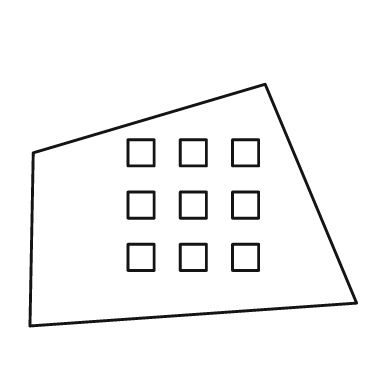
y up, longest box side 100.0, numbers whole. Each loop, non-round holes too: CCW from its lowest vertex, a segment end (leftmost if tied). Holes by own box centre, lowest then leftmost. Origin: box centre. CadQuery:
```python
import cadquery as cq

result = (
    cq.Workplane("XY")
    .moveTo(-50.0, -37.0)
    .lineTo(50.0, -30.0)
    .lineTo(22.0, 37.0)
    .lineTo(-49.0, 16.0)
    .close()
    .moveTo(-20.0, -20.0)
    .lineTo(-12.0, -20.0)
    .lineTo(-12.0, -12.0)
    .lineTo(-20.0, -12.0)
    .close()
    .moveTo(-4.0, -20.0)
    .lineTo(4.0, -20.0)
    .lineTo(4.0, -12.0)
    .lineTo(-4.0, -12.0)
    .close()
    .moveTo(12.0, -20.0)
    .lineTo(20.0, -20.0)
    .lineTo(20.0, -12.0)
    .lineTo(12.0, -12.0)
    .close()
    .moveTo(-20.0, -4.0)
    .lineTo(-12.0, -4.0)
    .lineTo(-12.0, 4.0)
    .lineTo(-20.0, 4.0)
    .close()
    .moveTo(-4.0, -4.0)
    .lineTo(4.0, -4.0)
    .lineTo(4.0, 4.0)
    .lineTo(-4.0, 4.0)
    .close()
    .moveTo(12.0, -4.0)
    .lineTo(20.0, -4.0)
    .lineTo(20.0, 4.0)
    .lineTo(12.0, 4.0)
    .close()
    .moveTo(-20.0, 12.0)
    .lineTo(-12.0, 12.0)
    .lineTo(-12.0, 20.0)
    .lineTo(-20.0, 20.0)
    .close()
    .moveTo(-4.0, 12.0)
    .lineTo(4.0, 12.0)
    .lineTo(4.0, 20.0)
    .lineTo(-4.0, 20.0)
    .close()
    .moveTo(12.0, 12.0)
    .lineTo(20.0, 12.0)
    .lineTo(20.0, 20.0)
    .lineTo(12.0, 20.0)
    .close()
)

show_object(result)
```